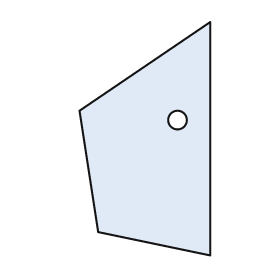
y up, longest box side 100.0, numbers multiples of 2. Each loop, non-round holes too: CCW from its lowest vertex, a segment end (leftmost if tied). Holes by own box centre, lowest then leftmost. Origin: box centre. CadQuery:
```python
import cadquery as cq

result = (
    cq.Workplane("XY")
    .moveTo(28.0, -50.0)
    .lineTo(28.0, 50.0)
    .lineTo(-28.0, 12.0)
    .lineTo(-20.0, -40.0)
    .close()
    .moveTo(14.0, 8.0)
    .circle(4.0)
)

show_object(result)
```